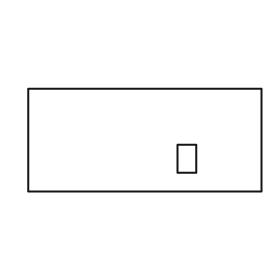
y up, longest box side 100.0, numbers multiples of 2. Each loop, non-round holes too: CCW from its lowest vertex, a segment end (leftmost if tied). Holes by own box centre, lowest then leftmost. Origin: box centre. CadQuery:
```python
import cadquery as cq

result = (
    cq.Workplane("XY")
    .moveTo(-50.0, -22.0)
    .lineTo(50.0, -22.0)
    .lineTo(50.0, 22.0)
    .lineTo(-50.0, 22.0)
    .close()
    .moveTo(14.0, -14.0)
    .lineTo(22.0, -14.0)
    .lineTo(22.0, -2.0)
    .lineTo(14.0, -2.0)
    .close()
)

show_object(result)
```